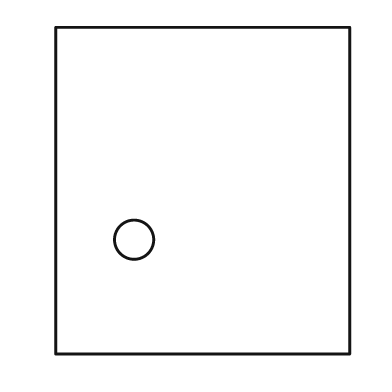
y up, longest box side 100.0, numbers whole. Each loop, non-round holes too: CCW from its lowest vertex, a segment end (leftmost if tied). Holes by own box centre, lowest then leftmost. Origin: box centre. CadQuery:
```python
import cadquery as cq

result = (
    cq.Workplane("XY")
    .moveTo(-45.0, -50.0)
    .lineTo(45.0, -50.0)
    .lineTo(45.0, 50.0)
    .lineTo(-45.0, 50.0)
    .close()
    .moveTo(-21.0, -15.0)
    .circle(6.0)
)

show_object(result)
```